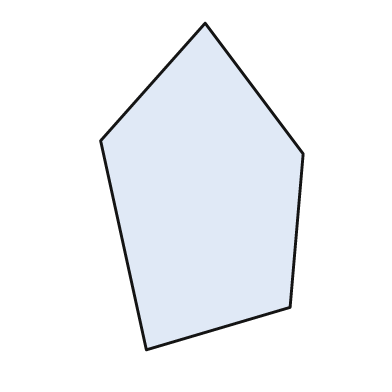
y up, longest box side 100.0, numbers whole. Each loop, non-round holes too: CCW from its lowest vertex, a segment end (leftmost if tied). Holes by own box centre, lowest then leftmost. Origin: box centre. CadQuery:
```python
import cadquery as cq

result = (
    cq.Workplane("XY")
    .moveTo(-17.0, -50.0)
    .lineTo(27.0, -37.0)
    .lineTo(31.0, 10.0)
    .lineTo(1.0, 50.0)
    .lineTo(-31.0, 14.0)
    .close()
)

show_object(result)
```